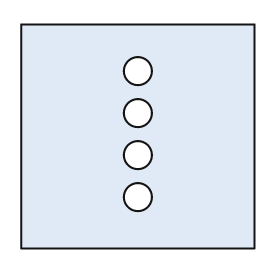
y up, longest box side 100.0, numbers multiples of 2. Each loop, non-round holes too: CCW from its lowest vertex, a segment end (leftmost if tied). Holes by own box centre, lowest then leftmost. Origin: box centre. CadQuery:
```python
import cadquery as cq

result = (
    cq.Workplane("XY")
    .moveTo(-50.0, -48.0)
    .lineTo(50.0, -48.0)
    .lineTo(50.0, 48.0)
    .lineTo(-50.0, 48.0)
    .close()
    .moveTo(0.0, -26.0)
    .circle(6.0)
    .moveTo(0.0, -8.0)
    .circle(6.0)
    .moveTo(0.0, 10.0)
    .circle(6.0)
    .moveTo(0.0, 28.0)
    .circle(6.0)
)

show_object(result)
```